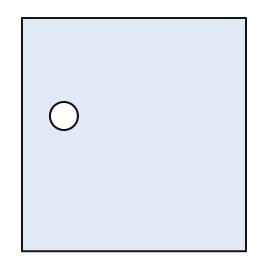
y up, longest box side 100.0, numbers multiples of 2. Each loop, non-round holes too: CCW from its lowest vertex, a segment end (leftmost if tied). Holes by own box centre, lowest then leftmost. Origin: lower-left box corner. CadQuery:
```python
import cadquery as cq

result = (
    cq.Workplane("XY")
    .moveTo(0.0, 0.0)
    .lineTo(96.0, 0.0)
    .lineTo(96.0, 100.0)
    .lineTo(0.0, 100.0)
    .close()
    .moveTo(18.0, 58.0)
    .circle(6.0)
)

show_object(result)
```